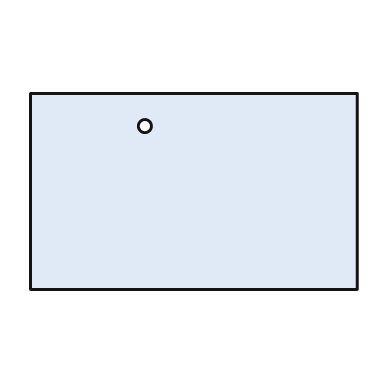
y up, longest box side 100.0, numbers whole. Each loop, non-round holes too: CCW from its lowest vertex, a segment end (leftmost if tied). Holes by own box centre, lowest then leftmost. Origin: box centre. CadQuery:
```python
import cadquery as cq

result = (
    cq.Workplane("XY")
    .moveTo(-50.0, -30.0)
    .lineTo(50.0, -30.0)
    .lineTo(50.0, 30.0)
    .lineTo(-50.0, 30.0)
    .close()
    .moveTo(-15.0, 20.0)
    .circle(2.0)
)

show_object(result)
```